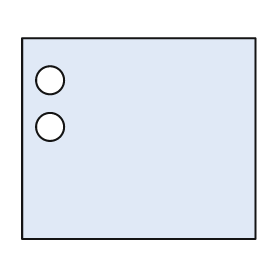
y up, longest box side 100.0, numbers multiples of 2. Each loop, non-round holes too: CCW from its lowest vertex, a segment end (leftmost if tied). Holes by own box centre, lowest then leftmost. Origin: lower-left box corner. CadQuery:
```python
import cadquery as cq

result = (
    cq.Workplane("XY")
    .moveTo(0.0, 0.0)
    .lineTo(100.0, 0.0)
    .lineTo(100.0, 86.0)
    .lineTo(0.0, 86.0)
    .close()
    .moveTo(12.0, 48.0)
    .circle(6.0)
    .moveTo(12.0, 68.0)
    .circle(6.0)
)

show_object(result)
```